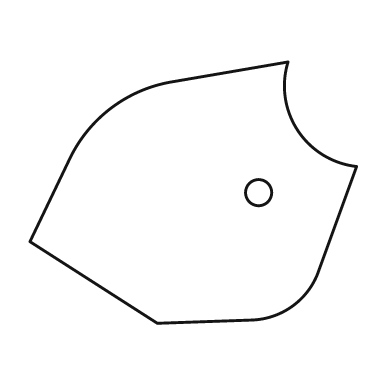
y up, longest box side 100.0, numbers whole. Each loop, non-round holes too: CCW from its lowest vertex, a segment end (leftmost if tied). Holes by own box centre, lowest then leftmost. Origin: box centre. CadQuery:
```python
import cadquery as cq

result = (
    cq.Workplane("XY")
    .moveTo(-11.0, -40.0)
    .lineTo(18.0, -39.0)
    .threePointArc((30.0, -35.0), (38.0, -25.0))
    .lineTo(50.0, 8.0)
    .threePointArc((32.0, 19.0), (29.0, 40.0))
    .lineTo(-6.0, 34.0)
    .threePointArc((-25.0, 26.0), (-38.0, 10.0))
    .lineTo(-50.0, -15.0)
    .close()
    .moveTo(20.0, 0.0)
    .circle(4.0)
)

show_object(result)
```